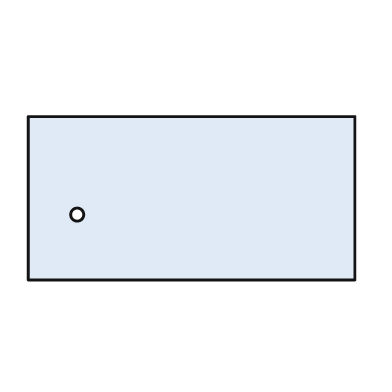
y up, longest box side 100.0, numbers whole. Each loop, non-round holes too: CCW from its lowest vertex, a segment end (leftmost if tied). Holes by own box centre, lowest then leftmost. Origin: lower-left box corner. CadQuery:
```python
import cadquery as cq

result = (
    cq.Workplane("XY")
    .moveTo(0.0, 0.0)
    .lineTo(100.0, 0.0)
    .lineTo(100.0, 50.0)
    .lineTo(0.0, 50.0)
    .close()
    .moveTo(15.0, 20.0)
    .circle(2.0)
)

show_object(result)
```